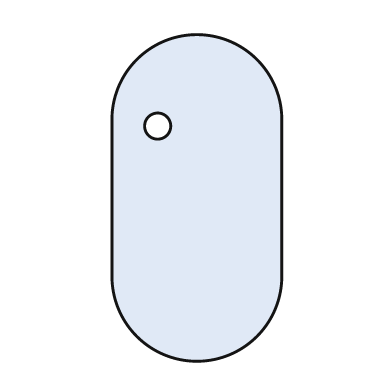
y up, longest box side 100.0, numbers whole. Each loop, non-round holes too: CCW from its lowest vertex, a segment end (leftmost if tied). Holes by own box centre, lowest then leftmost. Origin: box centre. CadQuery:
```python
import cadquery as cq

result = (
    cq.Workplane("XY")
    .moveTo(-26.0, -24.0)
    .threePointArc((0.0, -50.0), (26.0, -24.0))
    .lineTo(26.0, 24.0)
    .threePointArc((0.0, 50.0), (-26.0, 24.0))
    .close()
    .moveTo(-12.0, 22.0)
    .circle(4.0)
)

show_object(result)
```